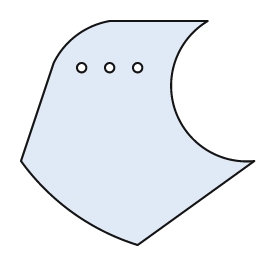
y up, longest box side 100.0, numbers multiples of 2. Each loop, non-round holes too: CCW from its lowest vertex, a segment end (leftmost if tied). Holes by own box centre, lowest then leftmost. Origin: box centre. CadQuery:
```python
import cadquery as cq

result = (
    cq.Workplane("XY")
    .moveTo(0.0, -48.0)
    .lineTo(50.0, -12.0)
    .threePointArc((16.0, 10.0), (30.0, 48.0))
    .lineTo(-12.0, 48.0)
    .threePointArc((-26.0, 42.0), (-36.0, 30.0))
    .lineTo(-50.0, -12.0)
    .threePointArc((-28.0, -34.0), (0.0, -48.0))
    .close()
    .moveTo(-24.0, 28.0)
    .circle(2.0)
    .moveTo(-12.0, 28.0)
    .circle(2.0)
    .moveTo(0.0, 28.0)
    .circle(2.0)
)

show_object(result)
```